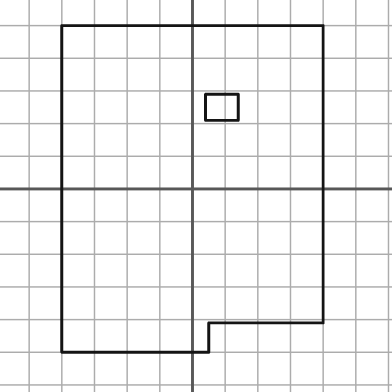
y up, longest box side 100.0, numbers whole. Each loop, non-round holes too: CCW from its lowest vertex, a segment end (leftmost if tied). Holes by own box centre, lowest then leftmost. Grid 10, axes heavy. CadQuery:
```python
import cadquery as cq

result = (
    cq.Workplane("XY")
    .moveTo(-40.0, -50.0)
    .lineTo(5.0, -50.0)
    .lineTo(5.0, -41.0)
    .lineTo(40.0, -41.0)
    .lineTo(40.0, 50.0)
    .lineTo(-40.0, 50.0)
    .close()
    .moveTo(4.0, 21.0)
    .lineTo(14.0, 21.0)
    .lineTo(14.0, 29.0)
    .lineTo(4.0, 29.0)
    .close()
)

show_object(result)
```